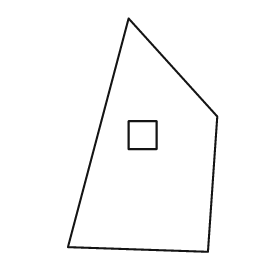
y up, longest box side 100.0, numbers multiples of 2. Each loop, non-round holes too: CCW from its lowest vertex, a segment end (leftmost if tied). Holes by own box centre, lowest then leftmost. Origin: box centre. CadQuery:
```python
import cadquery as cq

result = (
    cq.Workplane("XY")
    .moveTo(28.0, -50.0)
    .lineTo(32.0, 8.0)
    .lineTo(-6.0, 50.0)
    .lineTo(-32.0, -48.0)
    .close()
    .moveTo(-6.0, -6.0)
    .lineTo(6.0, -6.0)
    .lineTo(6.0, 6.0)
    .lineTo(-6.0, 6.0)
    .close()
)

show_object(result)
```